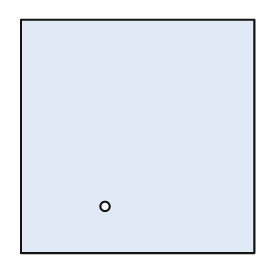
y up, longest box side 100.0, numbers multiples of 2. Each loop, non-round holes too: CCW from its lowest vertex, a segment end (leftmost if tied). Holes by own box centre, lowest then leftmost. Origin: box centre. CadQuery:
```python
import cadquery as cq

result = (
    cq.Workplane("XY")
    .moveTo(-50.0, -50.0)
    .lineTo(50.0, -50.0)
    .lineTo(50.0, 50.0)
    .lineTo(-50.0, 50.0)
    .close()
    .moveTo(-14.0, -30.0)
    .circle(2.0)
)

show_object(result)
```